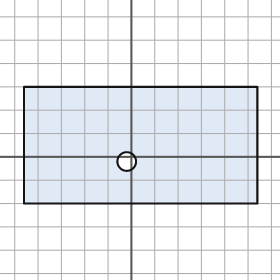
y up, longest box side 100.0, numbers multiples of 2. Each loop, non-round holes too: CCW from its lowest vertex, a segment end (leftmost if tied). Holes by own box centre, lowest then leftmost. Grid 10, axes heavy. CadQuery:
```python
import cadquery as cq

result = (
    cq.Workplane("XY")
    .moveTo(-46.0, -20.0)
    .lineTo(54.0, -20.0)
    .lineTo(54.0, 30.0)
    .lineTo(-46.0, 30.0)
    .close()
    .moveTo(-2.0, -2.0)
    .circle(4.0)
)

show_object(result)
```